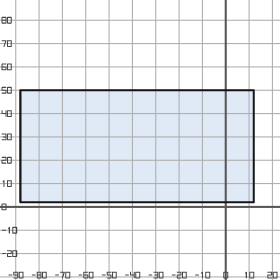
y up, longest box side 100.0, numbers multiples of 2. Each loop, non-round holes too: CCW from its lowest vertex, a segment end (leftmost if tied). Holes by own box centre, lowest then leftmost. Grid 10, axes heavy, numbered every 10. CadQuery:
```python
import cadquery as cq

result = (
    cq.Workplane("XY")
    .moveTo(-88.0, 2.0)
    .lineTo(12.0, 2.0)
    .lineTo(12.0, 50.0)
    .lineTo(-88.0, 50.0)
    .close()
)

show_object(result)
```